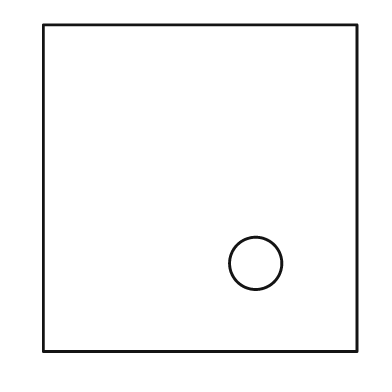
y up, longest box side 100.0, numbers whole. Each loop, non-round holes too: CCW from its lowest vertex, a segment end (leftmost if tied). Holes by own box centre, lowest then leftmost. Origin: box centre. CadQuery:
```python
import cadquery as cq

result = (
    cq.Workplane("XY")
    .moveTo(-48.0, -50.0)
    .lineTo(48.0, -50.0)
    .lineTo(48.0, 50.0)
    .lineTo(-48.0, 50.0)
    .close()
    .moveTo(17.0, -23.0)
    .circle(8.0)
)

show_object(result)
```